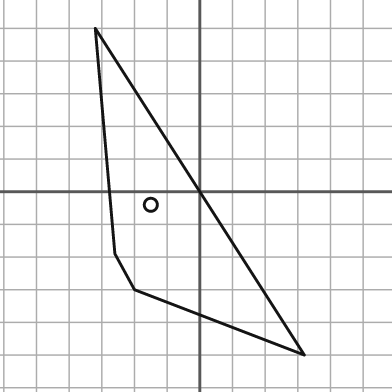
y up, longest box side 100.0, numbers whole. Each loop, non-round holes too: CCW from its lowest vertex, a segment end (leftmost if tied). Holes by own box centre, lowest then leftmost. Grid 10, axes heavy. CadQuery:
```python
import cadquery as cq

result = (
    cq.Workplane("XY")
    .moveTo(32.0, -50.0)
    .lineTo(-32.0, 50.0)
    .lineTo(-26.0, -19.0)
    .lineTo(-20.0, -30.0)
    .close()
    .moveTo(-15.0, -4.0)
    .circle(2.0)
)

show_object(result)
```